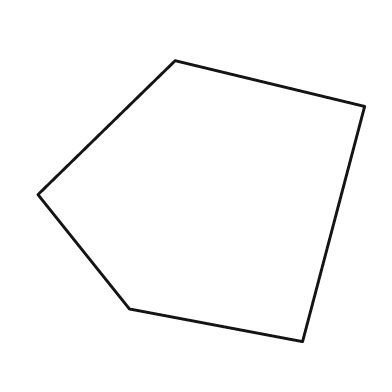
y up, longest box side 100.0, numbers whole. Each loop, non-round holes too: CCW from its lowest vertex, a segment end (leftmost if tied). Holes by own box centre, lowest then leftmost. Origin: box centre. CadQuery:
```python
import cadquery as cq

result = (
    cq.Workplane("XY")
    .moveTo(31.0, -43.0)
    .lineTo(50.0, 29.0)
    .lineTo(-8.0, 43.0)
    .lineTo(-50.0, 2.0)
    .lineTo(-22.0, -33.0)
    .close()
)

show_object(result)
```